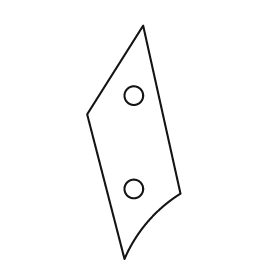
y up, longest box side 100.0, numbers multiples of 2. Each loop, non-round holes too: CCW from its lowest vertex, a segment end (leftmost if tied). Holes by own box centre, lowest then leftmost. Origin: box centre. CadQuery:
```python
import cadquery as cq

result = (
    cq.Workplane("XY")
    .moveTo(-4.0, -50.0)
    .threePointArc((6.0, -34.0), (20.0, -22.0))
    .lineTo(4.0, 50.0)
    .lineTo(-20.0, 12.0)
    .close()
    .moveTo(0.0, -20.0)
    .circle(4.0)
    .moveTo(0.0, 20.0)
    .circle(4.0)
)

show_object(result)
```